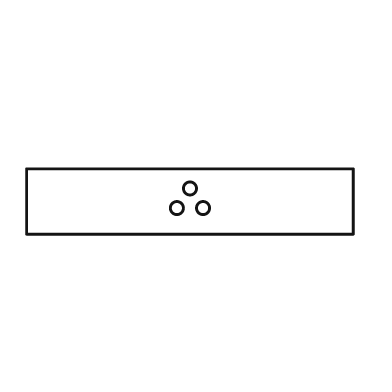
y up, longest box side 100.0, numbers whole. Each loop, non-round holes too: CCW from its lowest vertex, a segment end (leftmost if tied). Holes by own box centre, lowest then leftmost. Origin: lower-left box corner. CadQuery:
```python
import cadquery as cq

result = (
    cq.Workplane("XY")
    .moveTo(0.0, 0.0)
    .lineTo(100.0, 0.0)
    .lineTo(100.0, 20.0)
    .lineTo(0.0, 20.0)
    .close()
    .moveTo(46.0, 8.0)
    .circle(2.0)
    .moveTo(54.0, 8.0)
    .circle(2.0)
    .moveTo(50.0, 14.0)
    .circle(2.0)
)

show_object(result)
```